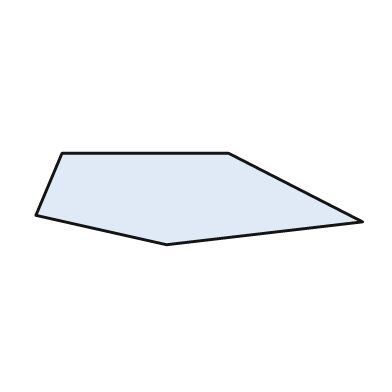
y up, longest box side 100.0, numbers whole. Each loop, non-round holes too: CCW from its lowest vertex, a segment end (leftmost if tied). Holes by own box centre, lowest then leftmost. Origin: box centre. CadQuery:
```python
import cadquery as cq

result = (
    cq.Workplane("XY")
    .moveTo(-10.0, -14.0)
    .lineTo(50.0, -7.0)
    .lineTo(9.0, 14.0)
    .lineTo(-42.0, 14.0)
    .lineTo(-50.0, -5.0)
    .close()
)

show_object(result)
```